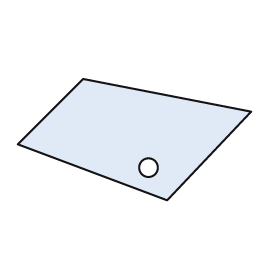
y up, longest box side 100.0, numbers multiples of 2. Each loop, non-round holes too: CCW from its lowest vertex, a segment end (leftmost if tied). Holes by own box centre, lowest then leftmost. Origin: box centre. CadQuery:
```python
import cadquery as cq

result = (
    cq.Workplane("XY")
    .moveTo(14.0, -26.0)
    .lineTo(50.0, 12.0)
    .lineTo(-22.0, 26.0)
    .lineTo(-50.0, -2.0)
    .close()
    .moveTo(6.0, -12.0)
    .circle(4.0)
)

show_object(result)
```